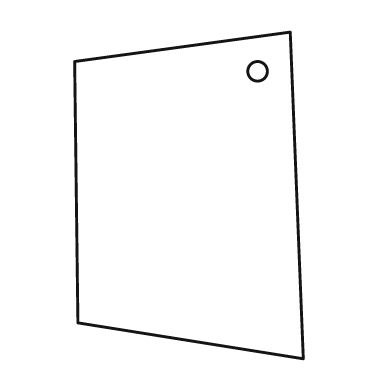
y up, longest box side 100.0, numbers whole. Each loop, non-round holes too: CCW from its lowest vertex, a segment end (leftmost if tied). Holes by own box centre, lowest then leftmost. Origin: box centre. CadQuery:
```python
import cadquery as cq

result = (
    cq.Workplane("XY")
    .moveTo(35.0, -50.0)
    .lineTo(31.0, 50.0)
    .lineTo(-35.0, 41.0)
    .lineTo(-34.0, -39.0)
    .close()
    .moveTo(21.0, 38.0)
    .circle(3.0)
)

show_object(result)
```